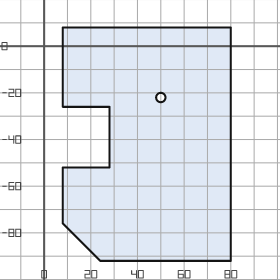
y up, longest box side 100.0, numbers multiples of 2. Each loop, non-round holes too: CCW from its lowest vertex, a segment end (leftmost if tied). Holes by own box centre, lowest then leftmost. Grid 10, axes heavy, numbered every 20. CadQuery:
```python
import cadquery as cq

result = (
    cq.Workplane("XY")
    .moveTo(24.0, -92.0)
    .lineTo(80.0, -92.0)
    .lineTo(80.0, 8.0)
    .lineTo(8.0, 8.0)
    .lineTo(8.0, -26.0)
    .lineTo(28.0, -26.0)
    .lineTo(28.0, -52.0)
    .lineTo(8.0, -52.0)
    .lineTo(8.0, -76.0)
    .close()
    .moveTo(50.0, -22.0)
    .circle(2.0)
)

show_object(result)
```